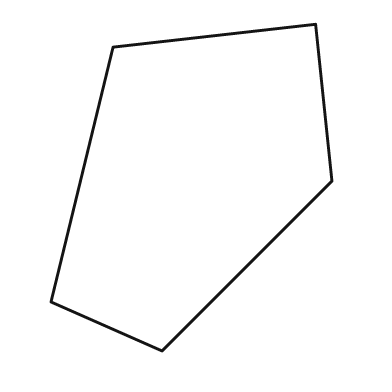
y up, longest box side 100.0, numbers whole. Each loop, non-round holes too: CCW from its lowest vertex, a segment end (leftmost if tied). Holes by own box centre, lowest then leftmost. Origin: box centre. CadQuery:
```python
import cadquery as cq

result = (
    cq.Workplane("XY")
    .moveTo(-9.0, -50.0)
    .lineTo(43.0, 2.0)
    .lineTo(38.0, 50.0)
    .lineTo(-24.0, 43.0)
    .lineTo(-43.0, -35.0)
    .close()
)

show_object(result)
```